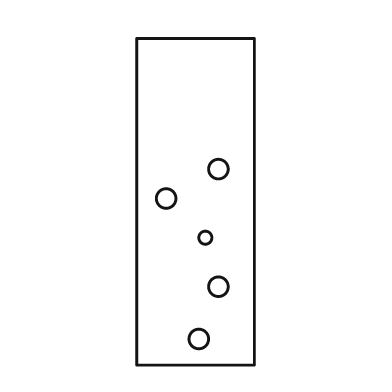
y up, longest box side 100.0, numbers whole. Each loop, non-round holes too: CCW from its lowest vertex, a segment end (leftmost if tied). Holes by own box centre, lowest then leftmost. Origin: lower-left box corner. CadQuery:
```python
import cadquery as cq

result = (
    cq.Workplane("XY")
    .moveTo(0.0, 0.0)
    .lineTo(36.0, 0.0)
    .lineTo(36.0, 100.0)
    .lineTo(0.0, 100.0)
    .close()
    .moveTo(19.0, 8.0)
    .circle(3.0)
    .moveTo(25.0, 24.0)
    .circle(3.0)
    .moveTo(21.0, 39.0)
    .circle(2.0)
    .moveTo(9.0, 51.0)
    .circle(3.0)
    .moveTo(25.0, 60.0)
    .circle(3.0)
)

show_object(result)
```